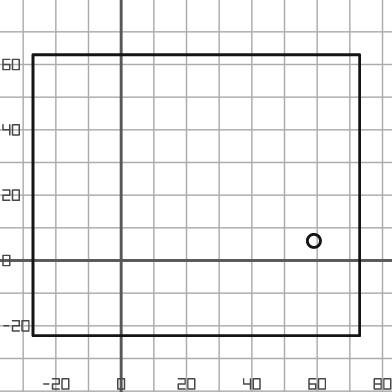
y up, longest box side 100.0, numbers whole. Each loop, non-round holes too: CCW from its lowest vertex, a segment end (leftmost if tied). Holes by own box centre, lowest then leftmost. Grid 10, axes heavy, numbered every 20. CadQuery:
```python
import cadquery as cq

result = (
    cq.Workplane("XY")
    .moveTo(-27.0, -23.0)
    .lineTo(73.0, -23.0)
    .lineTo(73.0, 63.0)
    .lineTo(-27.0, 63.0)
    .close()
    .moveTo(59.0, 6.0)
    .circle(2.0)
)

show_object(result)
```